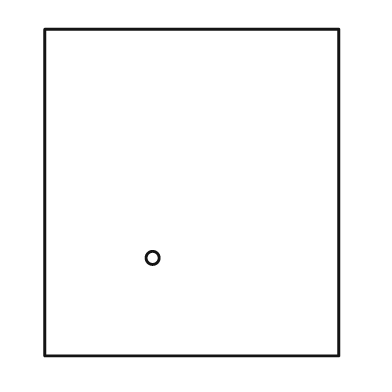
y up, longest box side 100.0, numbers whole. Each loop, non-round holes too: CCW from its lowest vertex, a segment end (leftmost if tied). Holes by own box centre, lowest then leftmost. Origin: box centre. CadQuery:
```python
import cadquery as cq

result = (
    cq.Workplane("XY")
    .moveTo(-45.0, -50.0)
    .lineTo(45.0, -50.0)
    .lineTo(45.0, 50.0)
    .lineTo(-45.0, 50.0)
    .close()
    .moveTo(-12.0, -20.0)
    .circle(2.0)
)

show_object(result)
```